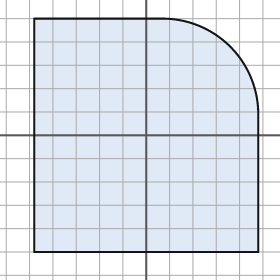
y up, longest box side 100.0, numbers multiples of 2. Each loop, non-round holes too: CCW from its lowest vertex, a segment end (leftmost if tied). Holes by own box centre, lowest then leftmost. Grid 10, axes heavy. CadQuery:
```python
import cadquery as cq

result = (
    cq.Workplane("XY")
    .moveTo(-48.0, -50.0)
    .lineTo(48.0, -50.0)
    .lineTo(48.0, 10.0)
    .threePointArc((36.0, 38.0), (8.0, 50.0))
    .lineTo(-48.0, 50.0)
    .close()
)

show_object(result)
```